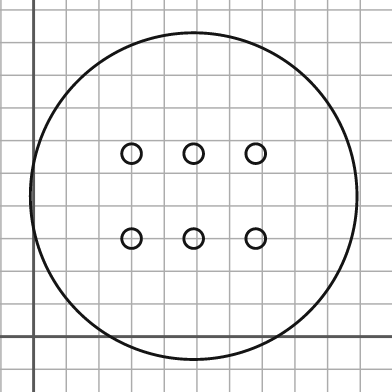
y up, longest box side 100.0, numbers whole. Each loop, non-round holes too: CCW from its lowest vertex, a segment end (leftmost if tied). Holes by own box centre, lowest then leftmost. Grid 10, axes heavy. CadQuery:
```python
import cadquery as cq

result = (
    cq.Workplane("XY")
    .moveTo(49.0, 43.0)
    .circle(50.0)
    .moveTo(30.0, 30.0)
    .circle(3.0)
    .moveTo(49.0, 30.0)
    .circle(3.0)
    .moveTo(68.0, 30.0)
    .circle(3.0)
    .moveTo(30.0, 56.0)
    .circle(3.0)
    .moveTo(49.0, 56.0)
    .circle(3.0)
    .moveTo(68.0, 56.0)
    .circle(3.0)
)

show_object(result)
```